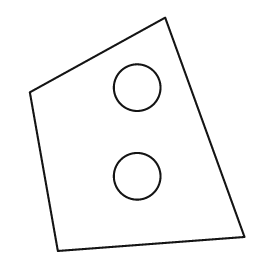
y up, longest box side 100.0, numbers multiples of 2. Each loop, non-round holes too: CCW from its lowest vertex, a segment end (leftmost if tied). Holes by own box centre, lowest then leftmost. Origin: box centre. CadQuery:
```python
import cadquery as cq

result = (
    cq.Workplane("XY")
    .moveTo(-34.0, -50.0)
    .lineTo(46.0, -44.0)
    .lineTo(12.0, 50.0)
    .lineTo(-46.0, 18.0)
    .close()
    .moveTo(0.0, -18.0)
    .circle(10.0)
    .moveTo(0.0, 20.0)
    .circle(10.0)
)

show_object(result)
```